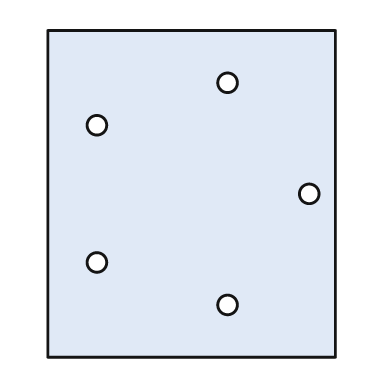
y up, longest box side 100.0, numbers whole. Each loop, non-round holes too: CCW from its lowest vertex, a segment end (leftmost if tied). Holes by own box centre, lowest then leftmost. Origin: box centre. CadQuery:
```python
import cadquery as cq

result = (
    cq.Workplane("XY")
    .moveTo(-44.0, -50.0)
    .lineTo(44.0, -50.0)
    .lineTo(44.0, 50.0)
    .lineTo(-44.0, 50.0)
    .close()
    .moveTo(11.0, -34.0)
    .circle(3.0)
    .moveTo(-29.0, -21.0)
    .circle(3.0)
    .moveTo(36.0, 0.0)
    .circle(3.0)
    .moveTo(-29.0, 21.0)
    .circle(3.0)
    .moveTo(11.0, 34.0)
    .circle(3.0)
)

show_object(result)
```